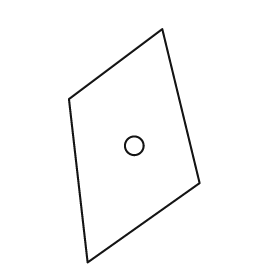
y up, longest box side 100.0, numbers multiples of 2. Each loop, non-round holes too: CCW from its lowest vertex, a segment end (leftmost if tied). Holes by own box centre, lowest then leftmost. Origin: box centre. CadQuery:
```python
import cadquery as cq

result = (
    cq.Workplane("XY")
    .moveTo(-20.0, -50.0)
    .lineTo(28.0, -16.0)
    .lineTo(12.0, 50.0)
    .lineTo(-28.0, 20.0)
    .close()
    .moveTo(0.0, 0.0)
    .circle(4.0)
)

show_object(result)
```